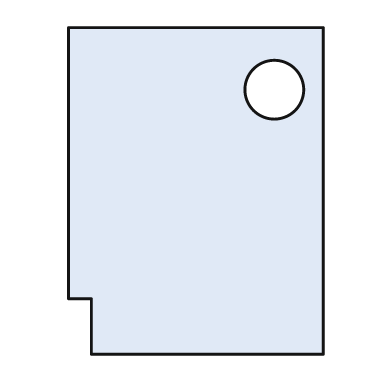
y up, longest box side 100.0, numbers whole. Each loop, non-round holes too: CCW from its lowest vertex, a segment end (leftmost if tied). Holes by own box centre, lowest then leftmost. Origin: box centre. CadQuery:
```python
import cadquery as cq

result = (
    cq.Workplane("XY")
    .moveTo(-32.0, -50.0)
    .lineTo(39.0, -50.0)
    .lineTo(39.0, 50.0)
    .lineTo(-39.0, 50.0)
    .lineTo(-39.0, -33.0)
    .lineTo(-32.0, -33.0)
    .close()
    .moveTo(24.0, 31.0)
    .circle(9.0)
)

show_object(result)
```